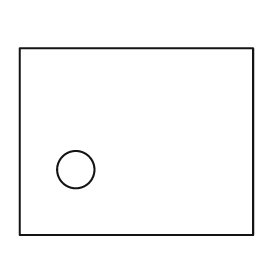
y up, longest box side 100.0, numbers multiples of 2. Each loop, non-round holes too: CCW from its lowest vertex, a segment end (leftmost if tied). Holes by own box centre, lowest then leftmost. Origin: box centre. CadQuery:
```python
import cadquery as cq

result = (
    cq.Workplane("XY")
    .moveTo(-50.0, -40.0)
    .lineTo(50.0, -40.0)
    .lineTo(50.0, 40.0)
    .lineTo(-50.0, 40.0)
    .close()
    .moveTo(-26.0, -12.0)
    .circle(8.0)
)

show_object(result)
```